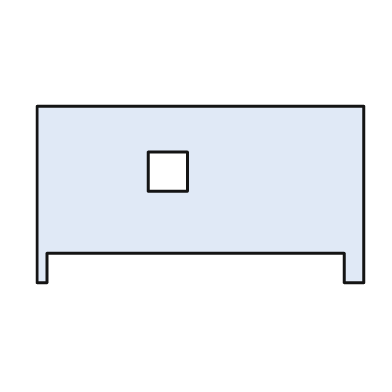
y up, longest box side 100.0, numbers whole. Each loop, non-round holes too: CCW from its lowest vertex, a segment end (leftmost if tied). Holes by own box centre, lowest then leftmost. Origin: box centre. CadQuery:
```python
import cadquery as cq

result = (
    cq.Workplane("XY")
    .moveTo(-50.0, -27.0)
    .lineTo(-47.0, -27.0)
    .lineTo(-47.0, -18.0)
    .lineTo(44.0, -18.0)
    .lineTo(44.0, -27.0)
    .lineTo(50.0, -27.0)
    .lineTo(50.0, 27.0)
    .lineTo(-50.0, 27.0)
    .close()
    .moveTo(-16.0, 1.0)
    .lineTo(-4.0, 1.0)
    .lineTo(-4.0, 13.0)
    .lineTo(-16.0, 13.0)
    .close()
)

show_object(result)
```